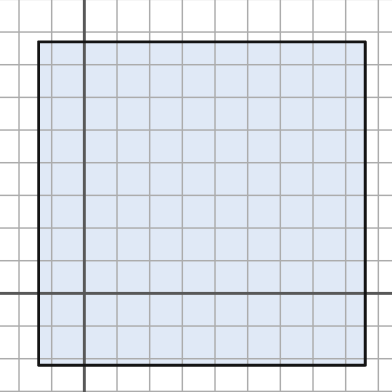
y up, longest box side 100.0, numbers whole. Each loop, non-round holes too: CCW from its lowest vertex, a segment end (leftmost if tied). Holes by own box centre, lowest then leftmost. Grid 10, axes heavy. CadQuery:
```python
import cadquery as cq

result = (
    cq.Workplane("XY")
    .moveTo(-14.0, -22.0)
    .lineTo(86.0, -22.0)
    .lineTo(86.0, 77.0)
    .lineTo(-14.0, 77.0)
    .close()
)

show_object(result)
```